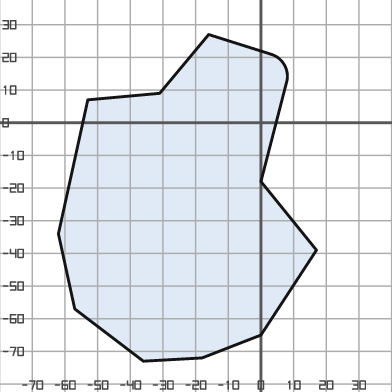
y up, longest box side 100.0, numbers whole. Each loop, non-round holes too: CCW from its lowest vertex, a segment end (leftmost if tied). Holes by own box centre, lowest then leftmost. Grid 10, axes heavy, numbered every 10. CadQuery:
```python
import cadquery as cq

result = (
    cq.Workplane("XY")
    .moveTo(-36.0, -73.0)
    .lineTo(-18.0, -72.0)
    .lineTo(0.0, -65.0)
    .lineTo(17.0, -39.0)
    .lineTo(0.0, -18.0)
    .lineTo(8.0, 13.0)
    .threePointArc((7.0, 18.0), (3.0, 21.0))
    .lineTo(-16.0, 27.0)
    .lineTo(-31.0, 9.0)
    .lineTo(-53.0, 7.0)
    .lineTo(-62.0, -34.0)
    .lineTo(-57.0, -57.0)
    .close()
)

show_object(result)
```